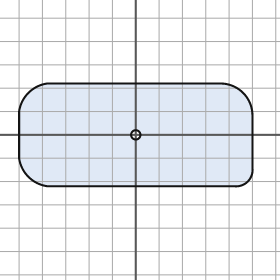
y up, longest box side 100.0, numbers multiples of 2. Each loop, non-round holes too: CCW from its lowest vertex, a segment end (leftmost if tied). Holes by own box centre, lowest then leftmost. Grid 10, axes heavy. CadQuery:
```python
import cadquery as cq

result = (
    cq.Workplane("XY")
    .moveTo(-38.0, -22.0)
    .lineTo(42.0, -22.0)
    .threePointArc((48.0, -20.0), (50.0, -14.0))
    .lineTo(50.0, 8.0)
    .threePointArc((46.0, 18.0), (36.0, 22.0))
    .lineTo(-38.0, 22.0)
    .threePointArc((-46.0, 18.0), (-50.0, 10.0))
    .lineTo(-50.0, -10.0)
    .threePointArc((-46.0, -18.0), (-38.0, -22.0))
    .close()
    .moveTo(0.0, 0.0)
    .circle(2.0)
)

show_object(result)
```